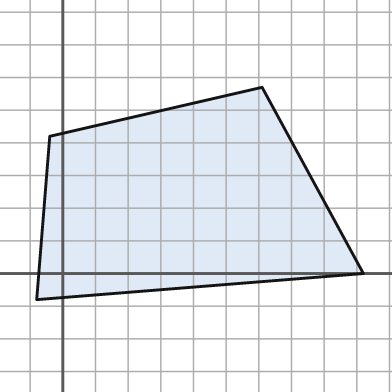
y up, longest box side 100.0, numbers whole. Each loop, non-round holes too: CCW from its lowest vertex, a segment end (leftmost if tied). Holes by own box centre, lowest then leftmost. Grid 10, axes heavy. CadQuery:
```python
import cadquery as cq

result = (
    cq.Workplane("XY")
    .moveTo(-8.0, -8.0)
    .lineTo(92.0, 0.0)
    .lineTo(61.0, 57.0)
    .lineTo(-4.0, 42.0)
    .close()
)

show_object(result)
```